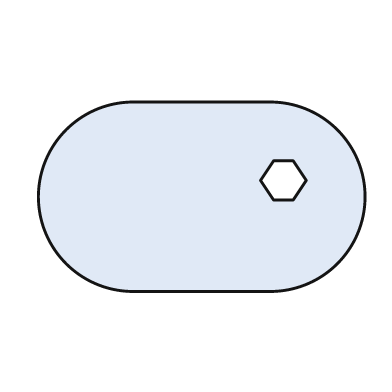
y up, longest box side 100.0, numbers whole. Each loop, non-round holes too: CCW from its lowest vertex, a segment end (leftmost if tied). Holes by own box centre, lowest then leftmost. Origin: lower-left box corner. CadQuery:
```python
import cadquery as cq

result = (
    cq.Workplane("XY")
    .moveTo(29.0, 0.0)
    .lineTo(71.0, 0.0)
    .threePointArc((100.0, 29.0), (71.0, 58.0))
    .lineTo(29.0, 58.0)
    .threePointArc((0.0, 29.0), (29.0, 0.0))
    .close()
    .moveTo(72.0, 28.0)
    .lineTo(78.0, 28.0)
    .lineTo(82.0, 34.0)
    .lineTo(78.0, 40.0)
    .lineTo(72.0, 40.0)
    .lineTo(68.0, 34.0)
    .close()
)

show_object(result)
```